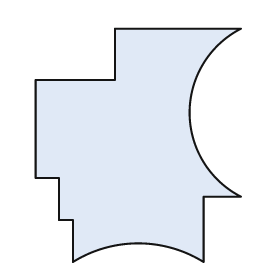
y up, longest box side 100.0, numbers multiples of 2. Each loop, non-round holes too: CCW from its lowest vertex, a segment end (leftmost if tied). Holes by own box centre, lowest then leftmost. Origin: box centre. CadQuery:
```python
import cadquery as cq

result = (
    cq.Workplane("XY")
    .moveTo(-28.0, -50.0)
    .threePointArc((0.0, -42.0), (28.0, -50.0))
    .lineTo(28.0, -22.0)
    .lineTo(44.0, -22.0)
    .threePointArc((22.0, 14.0), (44.0, 50.0))
    .lineTo(-10.0, 50.0)
    .lineTo(-10.0, 28.0)
    .lineTo(-44.0, 28.0)
    .lineTo(-44.0, -14.0)
    .lineTo(-34.0, -14.0)
    .lineTo(-34.0, -32.0)
    .lineTo(-28.0, -32.0)
    .close()
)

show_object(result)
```